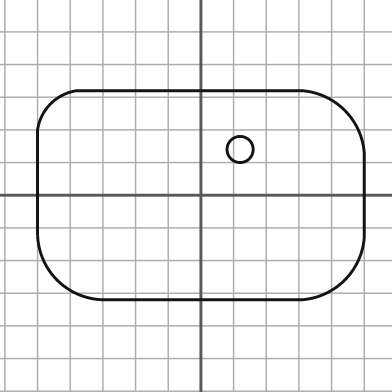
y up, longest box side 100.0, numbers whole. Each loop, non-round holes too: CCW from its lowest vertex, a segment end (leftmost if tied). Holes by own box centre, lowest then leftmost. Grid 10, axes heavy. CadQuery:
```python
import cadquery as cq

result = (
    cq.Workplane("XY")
    .moveTo(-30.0, -32.0)
    .lineTo(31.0, -32.0)
    .threePointArc((44.0, -26.0), (50.0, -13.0))
    .lineTo(50.0, 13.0)
    .threePointArc((44.0, 26.0), (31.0, 32.0))
    .lineTo(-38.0, 32.0)
    .threePointArc((-46.0, 28.0), (-50.0, 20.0))
    .lineTo(-50.0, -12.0)
    .threePointArc((-44.0, -26.0), (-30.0, -32.0))
    .close()
    .moveTo(12.0, 14.0)
    .circle(4.0)
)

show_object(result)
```